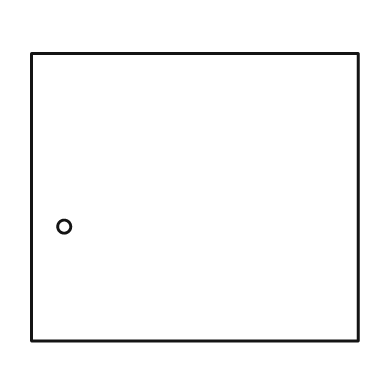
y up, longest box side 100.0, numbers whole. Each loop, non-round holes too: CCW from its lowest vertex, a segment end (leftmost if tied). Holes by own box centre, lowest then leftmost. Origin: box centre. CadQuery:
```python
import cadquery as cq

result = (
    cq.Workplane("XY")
    .moveTo(-50.0, -44.0)
    .lineTo(50.0, -44.0)
    .lineTo(50.0, 44.0)
    .lineTo(-50.0, 44.0)
    .close()
    .moveTo(-40.0, -9.0)
    .circle(2.0)
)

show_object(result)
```